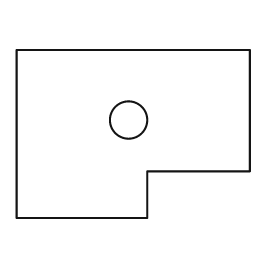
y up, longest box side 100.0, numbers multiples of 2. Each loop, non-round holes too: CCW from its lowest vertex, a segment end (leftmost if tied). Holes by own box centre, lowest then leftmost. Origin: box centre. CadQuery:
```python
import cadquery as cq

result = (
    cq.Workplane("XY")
    .moveTo(-50.0, -36.0)
    .lineTo(6.0, -36.0)
    .lineTo(6.0, -16.0)
    .lineTo(50.0, -16.0)
    .lineTo(50.0, 36.0)
    .lineTo(-50.0, 36.0)
    .close()
    .moveTo(-2.0, 6.0)
    .circle(8.0)
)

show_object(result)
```